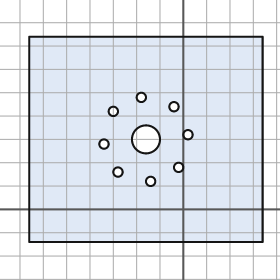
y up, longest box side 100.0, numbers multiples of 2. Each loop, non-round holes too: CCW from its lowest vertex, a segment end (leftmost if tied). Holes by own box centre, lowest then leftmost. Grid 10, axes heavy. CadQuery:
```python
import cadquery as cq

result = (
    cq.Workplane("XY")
    .moveTo(-66.0, -14.0)
    .lineTo(34.0, -14.0)
    .lineTo(34.0, 74.0)
    .lineTo(-66.0, 74.0)
    .close()
    .moveTo(-14.0, 12.0)
    .circle(2.0)
    .moveTo(-28.0, 16.0)
    .circle(2.0)
    .moveTo(-2.0, 18.0)
    .circle(2.0)
    .moveTo(-34.0, 28.0)
    .circle(2.0)
    .moveTo(-16.0, 30.0)
    .circle(6.0)
    .moveTo(2.0, 32.0)
    .circle(2.0)
    .moveTo(-30.0, 42.0)
    .circle(2.0)
    .moveTo(-4.0, 44.0)
    .circle(2.0)
    .moveTo(-18.0, 48.0)
    .circle(2.0)
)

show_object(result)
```